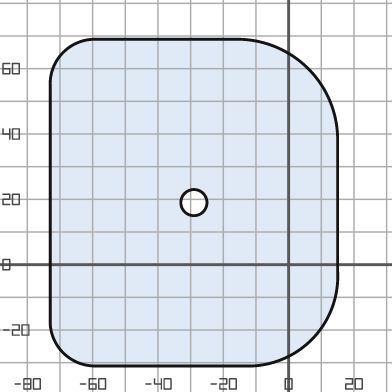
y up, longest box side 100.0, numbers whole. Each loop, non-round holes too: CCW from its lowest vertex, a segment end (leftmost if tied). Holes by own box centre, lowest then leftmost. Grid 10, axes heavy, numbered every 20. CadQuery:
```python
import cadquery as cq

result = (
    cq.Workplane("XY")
    .moveTo(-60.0, -31.0)
    .lineTo(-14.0, -31.0)
    .threePointArc((7.0, -23.0), (15.0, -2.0))
    .lineTo(15.0, 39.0)
    .threePointArc((6.0, 60.0), (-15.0, 69.0))
    .lineTo(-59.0, 69.0)
    .threePointArc((-69.0, 65.0), (-73.0, 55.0))
    .lineTo(-73.0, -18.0)
    .threePointArc((-69.0, -27.0), (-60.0, -31.0))
    .close()
    .moveTo(-29.0, 19.0)
    .circle(4.0)
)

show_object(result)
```